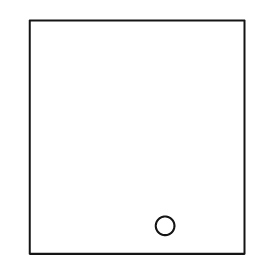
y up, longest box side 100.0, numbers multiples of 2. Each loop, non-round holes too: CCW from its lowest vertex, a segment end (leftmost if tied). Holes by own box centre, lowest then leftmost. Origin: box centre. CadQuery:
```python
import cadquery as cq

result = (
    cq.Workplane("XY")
    .moveTo(-46.0, -50.0)
    .lineTo(46.0, -50.0)
    .lineTo(46.0, 50.0)
    .lineTo(-46.0, 50.0)
    .close()
    .moveTo(12.0, -38.0)
    .circle(4.0)
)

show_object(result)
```